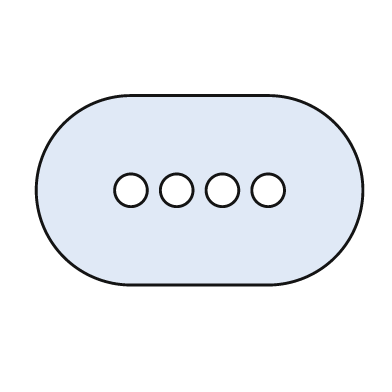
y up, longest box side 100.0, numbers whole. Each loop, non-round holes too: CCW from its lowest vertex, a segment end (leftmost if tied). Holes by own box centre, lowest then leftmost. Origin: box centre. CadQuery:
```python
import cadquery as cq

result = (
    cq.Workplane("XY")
    .moveTo(-21.0, -29.0)
    .lineTo(21.0, -29.0)
    .threePointArc((50.0, 0.0), (21.0, 29.0))
    .lineTo(-21.0, 29.0)
    .threePointArc((-50.0, 0.0), (-21.0, -29.0))
    .close()
    .moveTo(-21.0, 0.0)
    .circle(5.0)
    .moveTo(-7.0, 0.0)
    .circle(5.0)
    .moveTo(7.0, 0.0)
    .circle(5.0)
    .moveTo(21.0, 0.0)
    .circle(5.0)
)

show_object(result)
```